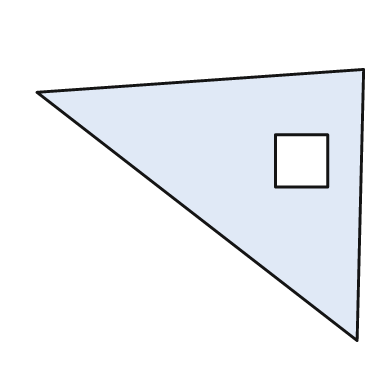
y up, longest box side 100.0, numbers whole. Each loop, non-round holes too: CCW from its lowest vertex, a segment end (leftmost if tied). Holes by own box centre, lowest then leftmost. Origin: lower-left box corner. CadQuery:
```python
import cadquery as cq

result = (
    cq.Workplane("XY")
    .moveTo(98.0, 0.0)
    .lineTo(100.0, 83.0)
    .lineTo(0.0, 76.0)
    .close()
    .moveTo(73.0, 47.0)
    .lineTo(89.0, 47.0)
    .lineTo(89.0, 63.0)
    .lineTo(73.0, 63.0)
    .close()
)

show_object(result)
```